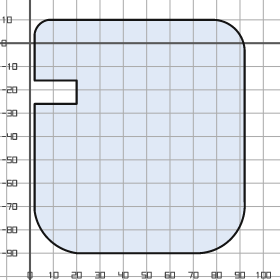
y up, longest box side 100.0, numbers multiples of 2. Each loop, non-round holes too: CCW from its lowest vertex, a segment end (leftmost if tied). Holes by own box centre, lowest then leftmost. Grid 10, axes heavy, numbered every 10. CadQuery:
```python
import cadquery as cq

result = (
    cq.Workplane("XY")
    .moveTo(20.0, -90.0)
    .lineTo(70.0, -90.0)
    .threePointArc((86.0, -84.0), (92.0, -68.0))
    .lineTo(92.0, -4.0)
    .threePointArc((88.0, 6.0), (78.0, 10.0))
    .lineTo(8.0, 10.0)
    .threePointArc((4.0, 8.0), (2.0, 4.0))
    .lineTo(2.0, -16.0)
    .lineTo(20.0, -16.0)
    .lineTo(20.0, -26.0)
    .lineTo(2.0, -26.0)
    .lineTo(2.0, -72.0)
    .threePointArc((8.0, -84.0), (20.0, -90.0))
    .close()
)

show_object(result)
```